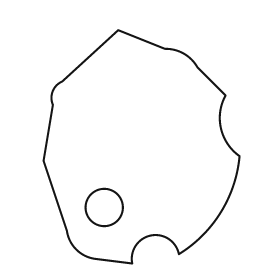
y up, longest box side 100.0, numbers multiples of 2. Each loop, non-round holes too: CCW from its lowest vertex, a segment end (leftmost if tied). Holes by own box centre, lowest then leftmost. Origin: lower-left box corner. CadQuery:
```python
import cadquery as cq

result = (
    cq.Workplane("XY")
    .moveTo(38.0, 0.0)
    .threePointArc((46.0, 12.0), (58.0, 4.0))
    .threePointArc((76.0, 22.0), (84.0, 46.0))
    .threePointArc((76.0, 58.0), (78.0, 72.0))
    .lineTo(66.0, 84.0)
    .threePointArc((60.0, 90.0), (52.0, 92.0))
    .lineTo(32.0, 100.0)
    .lineTo(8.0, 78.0)
    .threePointArc((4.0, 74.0), (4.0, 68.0))
    .lineTo(0.0, 44.0)
    .lineTo(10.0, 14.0)
    .threePointArc((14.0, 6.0), (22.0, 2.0))
    .close()
    .moveTo(26.0, 24.0)
    .circle(8.0)
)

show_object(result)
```